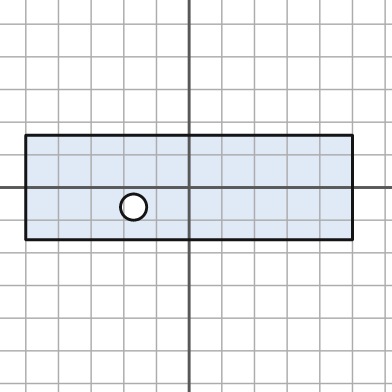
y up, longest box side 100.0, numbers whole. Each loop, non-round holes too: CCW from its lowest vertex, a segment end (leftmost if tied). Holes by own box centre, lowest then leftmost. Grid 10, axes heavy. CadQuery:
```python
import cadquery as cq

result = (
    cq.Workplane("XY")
    .moveTo(-50.0, -16.0)
    .lineTo(50.0, -16.0)
    .lineTo(50.0, 16.0)
    .lineTo(-50.0, 16.0)
    .close()
    .moveTo(-17.0, -6.0)
    .circle(4.0)
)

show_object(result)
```